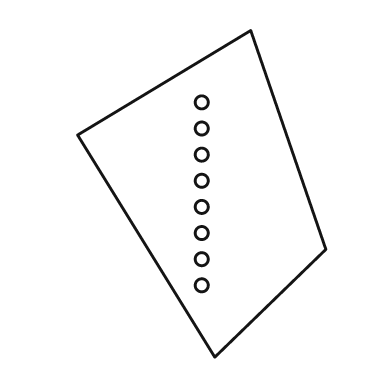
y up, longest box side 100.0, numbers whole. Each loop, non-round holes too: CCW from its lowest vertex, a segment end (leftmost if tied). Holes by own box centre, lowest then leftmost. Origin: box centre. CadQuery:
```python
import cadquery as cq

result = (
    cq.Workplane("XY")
    .moveTo(4.0, -50.0)
    .lineTo(38.0, -17.0)
    .lineTo(15.0, 50.0)
    .lineTo(-38.0, 18.0)
    .close()
    .moveTo(0.0, -28.0)
    .circle(2.0)
    .moveTo(0.0, -20.0)
    .circle(2.0)
    .moveTo(0.0, -12.0)
    .circle(2.0)
    .moveTo(0.0, -4.0)
    .circle(2.0)
    .moveTo(0.0, 4.0)
    .circle(2.0)
    .moveTo(0.0, 12.0)
    .circle(2.0)
    .moveTo(0.0, 20.0)
    .circle(2.0)
    .moveTo(0.0, 28.0)
    .circle(2.0)
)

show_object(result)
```